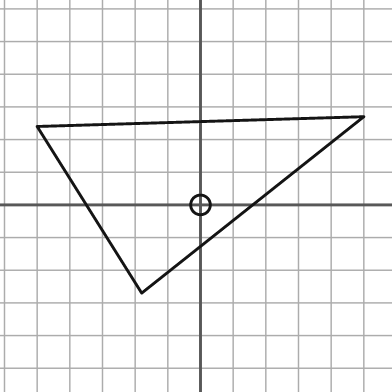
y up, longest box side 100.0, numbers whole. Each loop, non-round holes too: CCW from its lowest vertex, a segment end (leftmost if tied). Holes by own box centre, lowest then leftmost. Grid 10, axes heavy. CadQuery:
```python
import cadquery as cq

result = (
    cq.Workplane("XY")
    .moveTo(-18.0, -27.0)
    .lineTo(50.0, 27.0)
    .lineTo(-50.0, 24.0)
    .close()
    .moveTo(0.0, 0.0)
    .circle(3.0)
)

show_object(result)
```